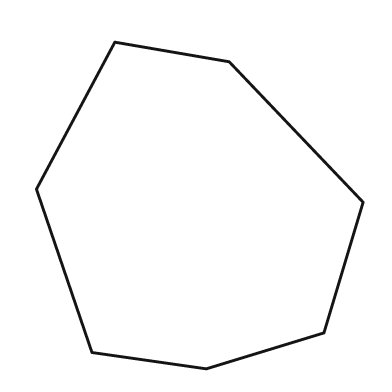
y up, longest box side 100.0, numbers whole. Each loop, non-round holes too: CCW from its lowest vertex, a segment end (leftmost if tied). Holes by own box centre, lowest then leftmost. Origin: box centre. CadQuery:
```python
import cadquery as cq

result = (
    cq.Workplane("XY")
    .moveTo(2.0, -50.0)
    .lineTo(38.0, -39.0)
    .lineTo(50.0, 1.0)
    .lineTo(9.0, 44.0)
    .lineTo(-26.0, 50.0)
    .lineTo(-50.0, 5.0)
    .lineTo(-33.0, -45.0)
    .close()
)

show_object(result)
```